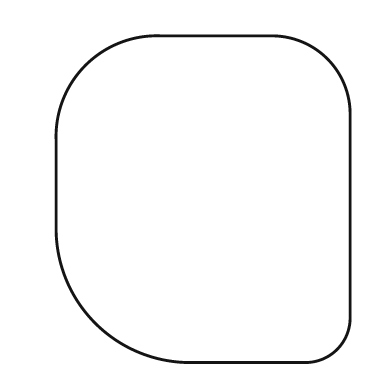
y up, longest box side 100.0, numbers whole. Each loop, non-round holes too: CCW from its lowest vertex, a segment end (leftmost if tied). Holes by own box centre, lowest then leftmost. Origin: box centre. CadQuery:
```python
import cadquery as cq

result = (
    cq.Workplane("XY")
    .moveTo(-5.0, -50.0)
    .lineTo(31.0, -50.0)
    .threePointArc((41.0, -46.0), (45.0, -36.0))
    .lineTo(45.0, 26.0)
    .threePointArc((38.0, 43.0), (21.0, 50.0))
    .lineTo(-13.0, 50.0)
    .threePointArc((-36.0, 41.0), (-45.0, 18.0))
    .lineTo(-45.0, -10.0)
    .threePointArc((-33.0, -38.0), (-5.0, -50.0))
    .close()
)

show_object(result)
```